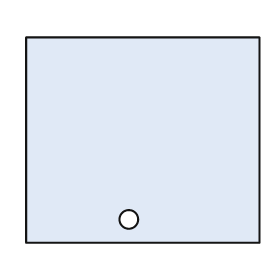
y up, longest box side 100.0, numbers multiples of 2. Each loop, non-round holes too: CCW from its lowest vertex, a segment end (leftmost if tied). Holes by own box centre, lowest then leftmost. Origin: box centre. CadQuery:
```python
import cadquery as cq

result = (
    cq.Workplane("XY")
    .moveTo(-50.0, -44.0)
    .lineTo(50.0, -44.0)
    .lineTo(50.0, 44.0)
    .lineTo(-50.0, 44.0)
    .close()
    .moveTo(-6.0, -34.0)
    .circle(4.0)
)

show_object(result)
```